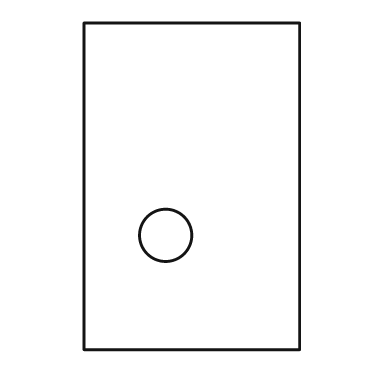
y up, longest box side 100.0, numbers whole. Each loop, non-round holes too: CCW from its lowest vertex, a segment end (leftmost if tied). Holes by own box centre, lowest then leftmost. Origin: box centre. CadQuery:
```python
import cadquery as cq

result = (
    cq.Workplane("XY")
    .moveTo(-33.0, -50.0)
    .lineTo(33.0, -50.0)
    .lineTo(33.0, 50.0)
    .lineTo(-33.0, 50.0)
    .close()
    .moveTo(-8.0, -15.0)
    .circle(8.0)
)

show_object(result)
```